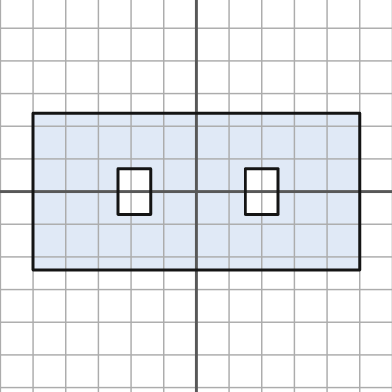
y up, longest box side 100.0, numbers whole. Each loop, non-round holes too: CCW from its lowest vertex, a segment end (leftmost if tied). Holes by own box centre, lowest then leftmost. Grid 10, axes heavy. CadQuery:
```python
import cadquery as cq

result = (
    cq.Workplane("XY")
    .moveTo(-50.0, -24.0)
    .lineTo(50.0, -24.0)
    .lineTo(50.0, 24.0)
    .lineTo(-50.0, 24.0)
    .close()
    .moveTo(-24.0, -7.0)
    .lineTo(-14.0, -7.0)
    .lineTo(-14.0, 7.0)
    .lineTo(-24.0, 7.0)
    .close()
    .moveTo(15.0, -7.0)
    .lineTo(25.0, -7.0)
    .lineTo(25.0, 7.0)
    .lineTo(15.0, 7.0)
    .close()
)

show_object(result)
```